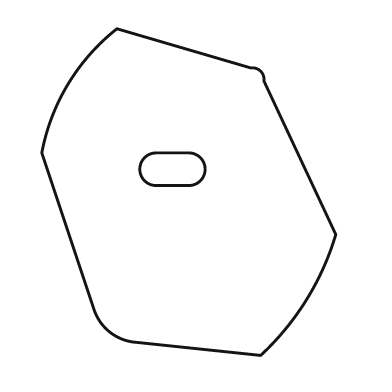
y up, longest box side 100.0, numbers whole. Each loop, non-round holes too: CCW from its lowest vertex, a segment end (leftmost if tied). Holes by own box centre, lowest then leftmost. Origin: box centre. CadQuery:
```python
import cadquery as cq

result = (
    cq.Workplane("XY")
    .moveTo(22.0, -50.0)
    .threePointArc((36.0, -33.0), (45.0, -13.0))
    .lineTo(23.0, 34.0)
    .threePointArc((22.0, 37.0), (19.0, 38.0))
    .lineTo(-22.0, 50.0)
    .threePointArc((-37.0, 33.0), (-45.0, 12.0))
    .lineTo(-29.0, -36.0)
    .threePointArc((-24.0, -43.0), (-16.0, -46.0))
    .close()
    .moveTo(-10.0, 2.0)
    .lineTo(0.0, 2.0)
    .threePointArc((5.0, 7.0), (0.0, 12.0))
    .lineTo(-10.0, 12.0)
    .threePointArc((-15.0, 7.0), (-10.0, 2.0))
    .close()
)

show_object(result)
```